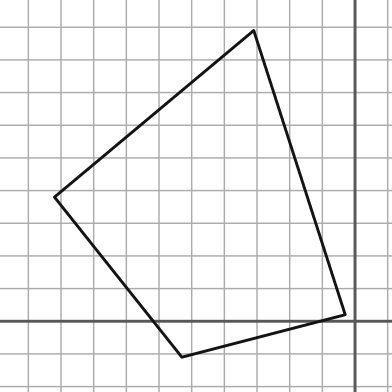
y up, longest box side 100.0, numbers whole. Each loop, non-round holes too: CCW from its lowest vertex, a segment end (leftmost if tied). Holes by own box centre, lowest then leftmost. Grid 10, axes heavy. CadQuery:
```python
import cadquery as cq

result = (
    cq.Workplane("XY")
    .moveTo(-53.0, -11.0)
    .lineTo(-3.0, 2.0)
    .lineTo(-31.0, 89.0)
    .lineTo(-92.0, 38.0)
    .close()
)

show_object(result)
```